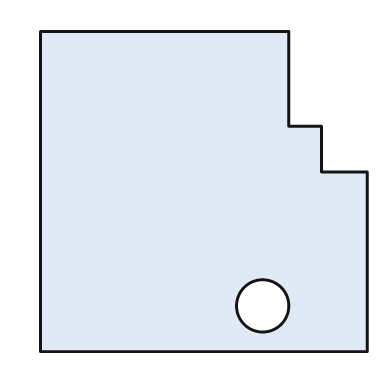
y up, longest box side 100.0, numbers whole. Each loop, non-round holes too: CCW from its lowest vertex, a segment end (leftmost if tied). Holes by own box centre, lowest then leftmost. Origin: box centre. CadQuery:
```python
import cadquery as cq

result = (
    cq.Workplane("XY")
    .moveTo(-50.0, -49.0)
    .lineTo(50.0, -49.0)
    .lineTo(50.0, 6.0)
    .lineTo(36.0, 6.0)
    .lineTo(36.0, 20.0)
    .lineTo(26.0, 20.0)
    .lineTo(26.0, 49.0)
    .lineTo(-50.0, 49.0)
    .close()
    .moveTo(18.0, -35.0)
    .circle(8.0)
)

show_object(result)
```